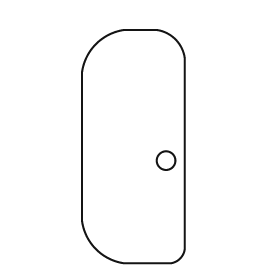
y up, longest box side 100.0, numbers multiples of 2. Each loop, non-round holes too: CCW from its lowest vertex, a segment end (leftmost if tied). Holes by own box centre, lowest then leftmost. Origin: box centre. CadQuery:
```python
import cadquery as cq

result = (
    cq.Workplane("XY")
    .moveTo(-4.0, -50.0)
    .lineTo(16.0, -50.0)
    .threePointArc((20.0, -48.0), (22.0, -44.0))
    .lineTo(22.0, 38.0)
    .threePointArc((18.0, 46.0), (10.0, 50.0))
    .lineTo(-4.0, 50.0)
    .threePointArc((-16.0, 44.0), (-22.0, 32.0))
    .lineTo(-22.0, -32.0)
    .threePointArc((-16.0, -44.0), (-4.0, -50.0))
    .close()
    .moveTo(14.0, -6.0)
    .circle(4.0)
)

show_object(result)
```